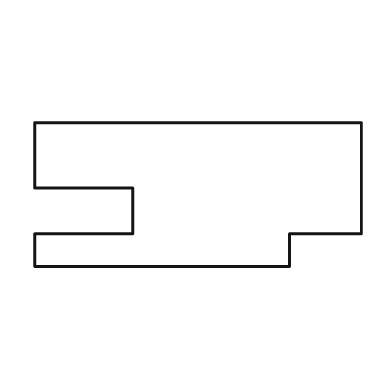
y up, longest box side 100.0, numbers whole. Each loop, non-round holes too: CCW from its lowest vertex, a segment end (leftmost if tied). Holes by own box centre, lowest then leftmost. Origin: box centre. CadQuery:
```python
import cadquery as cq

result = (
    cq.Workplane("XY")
    .moveTo(-50.0, -22.0)
    .lineTo(28.0, -22.0)
    .lineTo(28.0, -12.0)
    .lineTo(50.0, -12.0)
    .lineTo(50.0, 22.0)
    .lineTo(-50.0, 22.0)
    .lineTo(-50.0, 2.0)
    .lineTo(-20.0, 2.0)
    .lineTo(-20.0, -12.0)
    .lineTo(-50.0, -12.0)
    .close()
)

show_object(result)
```